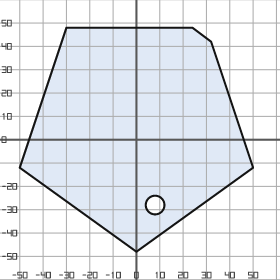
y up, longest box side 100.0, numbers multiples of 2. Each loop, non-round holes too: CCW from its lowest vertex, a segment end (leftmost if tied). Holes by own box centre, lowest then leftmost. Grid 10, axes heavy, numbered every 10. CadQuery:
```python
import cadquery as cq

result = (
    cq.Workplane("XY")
    .moveTo(0.0, -48.0)
    .lineTo(50.0, -12.0)
    .lineTo(32.0, 42.0)
    .lineTo(24.0, 48.0)
    .lineTo(-30.0, 48.0)
    .lineTo(-50.0, -12.0)
    .close()
    .moveTo(8.0, -28.0)
    .circle(4.0)
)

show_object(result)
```